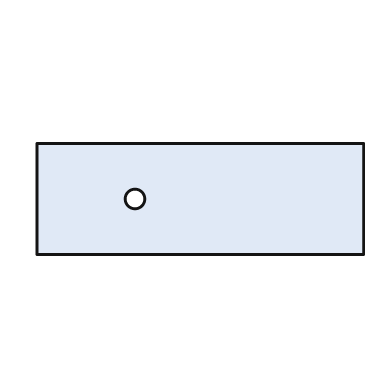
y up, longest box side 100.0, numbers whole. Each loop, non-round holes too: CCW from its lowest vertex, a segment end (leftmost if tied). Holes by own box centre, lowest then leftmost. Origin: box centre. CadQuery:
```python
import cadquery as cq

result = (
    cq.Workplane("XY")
    .moveTo(-50.0, -17.0)
    .lineTo(50.0, -17.0)
    .lineTo(50.0, 17.0)
    .lineTo(-50.0, 17.0)
    .close()
    .moveTo(-20.0, 0.0)
    .circle(3.0)
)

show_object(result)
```